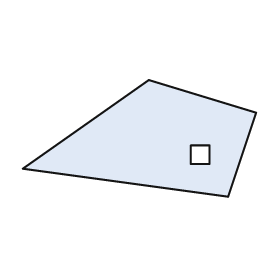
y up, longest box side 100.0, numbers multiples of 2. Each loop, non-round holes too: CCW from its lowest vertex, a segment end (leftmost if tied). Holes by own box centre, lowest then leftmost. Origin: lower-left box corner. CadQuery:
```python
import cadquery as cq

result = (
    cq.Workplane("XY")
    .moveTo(88.0, 0.0)
    .lineTo(100.0, 36.0)
    .lineTo(54.0, 50.0)
    .lineTo(0.0, 12.0)
    .close()
    .moveTo(72.0, 14.0)
    .lineTo(80.0, 14.0)
    .lineTo(80.0, 22.0)
    .lineTo(72.0, 22.0)
    .close()
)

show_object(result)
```